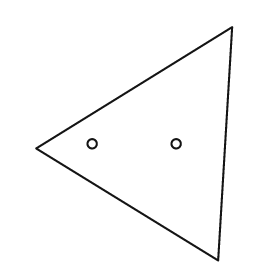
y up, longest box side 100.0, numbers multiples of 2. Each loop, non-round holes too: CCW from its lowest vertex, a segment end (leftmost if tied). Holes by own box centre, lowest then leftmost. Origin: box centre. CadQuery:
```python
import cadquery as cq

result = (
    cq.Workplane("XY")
    .moveTo(36.0, -50.0)
    .lineTo(42.0, 50.0)
    .lineTo(-42.0, -2.0)
    .close()
    .moveTo(-18.0, 0.0)
    .circle(2.0)
    .moveTo(18.0, 0.0)
    .circle(2.0)
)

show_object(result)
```